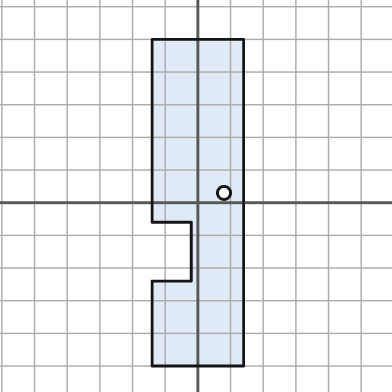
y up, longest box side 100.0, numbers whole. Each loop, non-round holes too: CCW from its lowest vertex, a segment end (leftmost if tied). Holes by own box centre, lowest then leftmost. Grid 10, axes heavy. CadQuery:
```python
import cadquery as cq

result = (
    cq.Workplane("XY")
    .moveTo(-14.0, -50.0)
    .lineTo(14.0, -50.0)
    .lineTo(14.0, 50.0)
    .lineTo(-14.0, 50.0)
    .lineTo(-14.0, -6.0)
    .lineTo(-2.0, -6.0)
    .lineTo(-2.0, -24.0)
    .lineTo(-14.0, -24.0)
    .close()
    .moveTo(8.0, 3.0)
    .circle(2.0)
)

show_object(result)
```